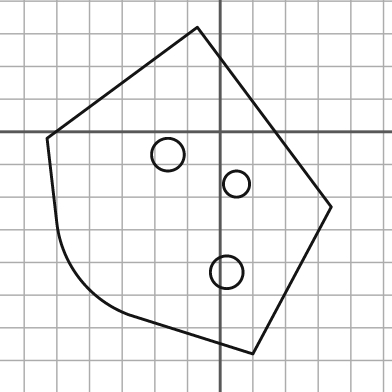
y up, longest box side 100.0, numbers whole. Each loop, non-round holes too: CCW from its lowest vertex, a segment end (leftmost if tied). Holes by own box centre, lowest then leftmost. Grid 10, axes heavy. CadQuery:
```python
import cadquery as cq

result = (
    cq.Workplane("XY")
    .moveTo(10.0, -68.0)
    .lineTo(34.0, -23.0)
    .lineTo(-7.0, 32.0)
    .lineTo(-53.0, -2.0)
    .lineTo(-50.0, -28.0)
    .threePointArc((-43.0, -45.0), (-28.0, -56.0))
    .close()
    .moveTo(2.0, -43.0)
    .circle(5.0)
    .moveTo(5.0, -16.0)
    .circle(4.0)
    .moveTo(-16.0, -7.0)
    .circle(5.0)
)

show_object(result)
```